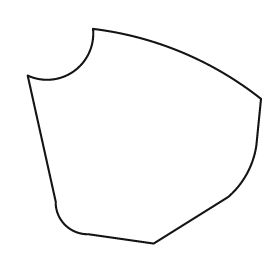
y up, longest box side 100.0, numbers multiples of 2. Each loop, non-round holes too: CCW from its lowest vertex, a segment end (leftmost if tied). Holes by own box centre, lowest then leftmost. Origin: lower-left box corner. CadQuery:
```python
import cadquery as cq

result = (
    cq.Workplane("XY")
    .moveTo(54.0, 0.0)
    .lineTo(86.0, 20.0)
    .threePointArc((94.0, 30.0), (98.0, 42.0))
    .lineTo(100.0, 62.0)
    .threePointArc((66.0, 82.0), (28.0, 92.0))
    .threePointArc((20.0, 74.0), (0.0, 72.0))
    .lineTo(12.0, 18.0)
    .threePointArc((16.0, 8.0), (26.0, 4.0))
    .close()
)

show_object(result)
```